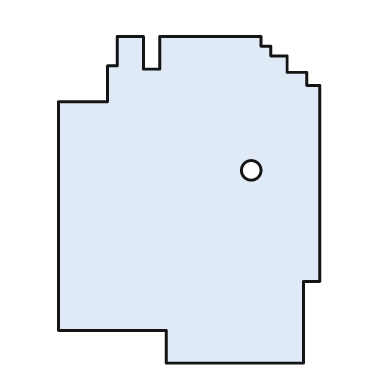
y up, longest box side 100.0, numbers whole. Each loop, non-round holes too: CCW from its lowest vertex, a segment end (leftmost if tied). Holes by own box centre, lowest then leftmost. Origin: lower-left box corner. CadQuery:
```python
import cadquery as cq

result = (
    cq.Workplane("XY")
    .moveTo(33.0, 0.0)
    .lineTo(75.0, 0.0)
    .lineTo(75.0, 25.0)
    .lineTo(80.0, 25.0)
    .lineTo(80.0, 85.0)
    .lineTo(76.0, 85.0)
    .lineTo(76.0, 89.0)
    .lineTo(70.0, 89.0)
    .lineTo(70.0, 94.0)
    .lineTo(65.0, 94.0)
    .lineTo(65.0, 97.0)
    .lineTo(62.0, 97.0)
    .lineTo(62.0, 100.0)
    .lineTo(31.0, 100.0)
    .lineTo(31.0, 90.0)
    .lineTo(26.0, 90.0)
    .lineTo(26.0, 100.0)
    .lineTo(18.0, 100.0)
    .lineTo(18.0, 91.0)
    .lineTo(15.0, 91.0)
    .lineTo(15.0, 80.0)
    .lineTo(0.0, 80.0)
    .lineTo(0.0, 10.0)
    .lineTo(33.0, 10.0)
    .close()
    .moveTo(59.0, 59.0)
    .circle(3.0)
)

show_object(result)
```